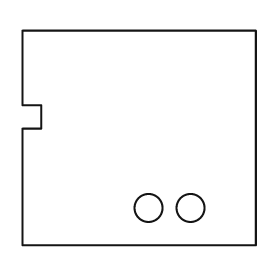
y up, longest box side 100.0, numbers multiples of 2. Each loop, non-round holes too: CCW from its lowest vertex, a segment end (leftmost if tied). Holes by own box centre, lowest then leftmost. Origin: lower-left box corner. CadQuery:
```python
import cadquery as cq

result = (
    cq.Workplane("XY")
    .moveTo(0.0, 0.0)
    .lineTo(100.0, 0.0)
    .lineTo(100.0, 92.0)
    .lineTo(0.0, 92.0)
    .lineTo(0.0, 60.0)
    .lineTo(8.0, 60.0)
    .lineTo(8.0, 50.0)
    .lineTo(0.0, 50.0)
    .close()
    .moveTo(54.0, 16.0)
    .circle(6.0)
    .moveTo(72.0, 16.0)
    .circle(6.0)
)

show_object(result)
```